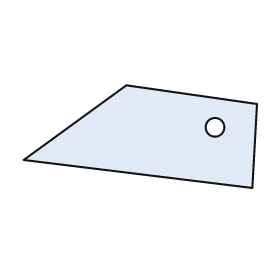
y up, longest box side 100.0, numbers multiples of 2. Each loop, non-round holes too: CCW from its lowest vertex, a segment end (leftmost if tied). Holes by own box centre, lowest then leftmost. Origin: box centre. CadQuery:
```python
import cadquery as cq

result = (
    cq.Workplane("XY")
    .moveTo(48.0, -22.0)
    .lineTo(50.0, 14.0)
    .lineTo(-6.0, 22.0)
    .lineTo(-50.0, -10.0)
    .close()
    .moveTo(32.0, 4.0)
    .circle(4.0)
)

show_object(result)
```